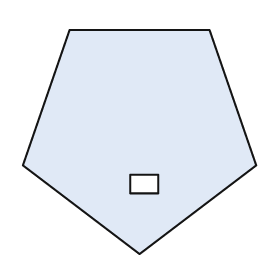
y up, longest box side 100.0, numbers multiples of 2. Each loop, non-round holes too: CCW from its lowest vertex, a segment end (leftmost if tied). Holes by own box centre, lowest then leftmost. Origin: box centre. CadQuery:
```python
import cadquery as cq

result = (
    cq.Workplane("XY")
    .moveTo(0.0, -48.0)
    .lineTo(50.0, -10.0)
    .lineTo(30.0, 48.0)
    .lineTo(-30.0, 48.0)
    .lineTo(-50.0, -10.0)
    .close()
    .moveTo(-4.0, -22.0)
    .lineTo(8.0, -22.0)
    .lineTo(8.0, -14.0)
    .lineTo(-4.0, -14.0)
    .close()
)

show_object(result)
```